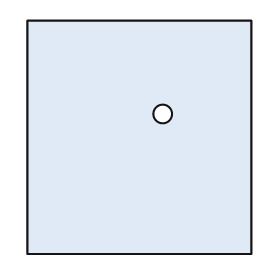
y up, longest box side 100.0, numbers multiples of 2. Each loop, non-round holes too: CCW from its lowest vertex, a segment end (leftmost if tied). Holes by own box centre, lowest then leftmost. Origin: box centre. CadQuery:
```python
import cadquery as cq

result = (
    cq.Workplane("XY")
    .moveTo(-48.0, -50.0)
    .lineTo(48.0, -50.0)
    .lineTo(48.0, 50.0)
    .lineTo(-48.0, 50.0)
    .close()
    .moveTo(10.0, 10.0)
    .circle(4.0)
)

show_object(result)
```